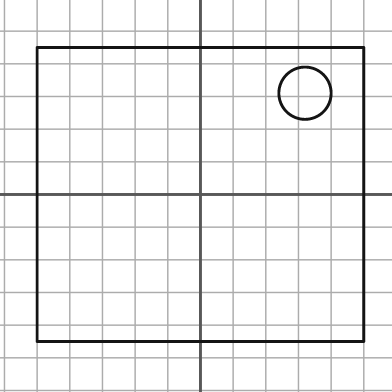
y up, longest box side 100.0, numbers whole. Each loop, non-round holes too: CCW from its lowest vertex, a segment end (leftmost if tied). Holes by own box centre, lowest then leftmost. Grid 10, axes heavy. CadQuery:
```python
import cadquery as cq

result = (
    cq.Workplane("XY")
    .moveTo(-50.0, -45.0)
    .lineTo(50.0, -45.0)
    .lineTo(50.0, 45.0)
    .lineTo(-50.0, 45.0)
    .close()
    .moveTo(32.0, 31.0)
    .circle(8.0)
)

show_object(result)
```